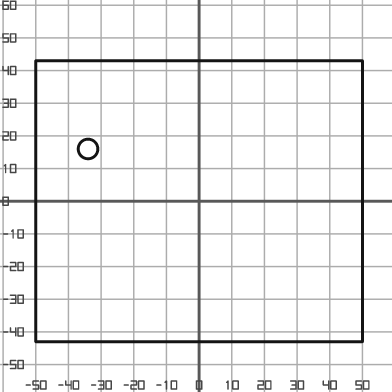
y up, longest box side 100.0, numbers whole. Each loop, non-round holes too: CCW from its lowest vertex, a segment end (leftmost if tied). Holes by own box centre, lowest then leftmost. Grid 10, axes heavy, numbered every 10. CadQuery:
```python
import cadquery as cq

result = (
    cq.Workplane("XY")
    .moveTo(-50.0, -43.0)
    .lineTo(50.0, -43.0)
    .lineTo(50.0, 43.0)
    .lineTo(-50.0, 43.0)
    .close()
    .moveTo(-34.0, 16.0)
    .circle(3.0)
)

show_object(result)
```